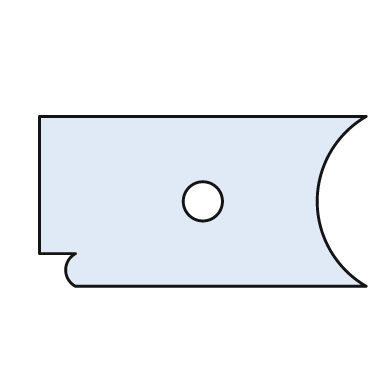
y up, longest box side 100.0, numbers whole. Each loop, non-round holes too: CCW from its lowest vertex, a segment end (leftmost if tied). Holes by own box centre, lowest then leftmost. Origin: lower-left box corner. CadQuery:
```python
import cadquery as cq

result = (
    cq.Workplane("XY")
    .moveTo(11.0, 0.0)
    .lineTo(100.0, 0.0)
    .threePointArc((85.0, 26.0), (100.0, 52.0))
    .lineTo(0.0, 52.0)
    .lineTo(0.0, 10.0)
    .lineTo(11.0, 10.0)
    .threePointArc((8.0, 5.0), (11.0, 0.0))
    .close()
    .moveTo(50.0, 26.0)
    .circle(6.0)
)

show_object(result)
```